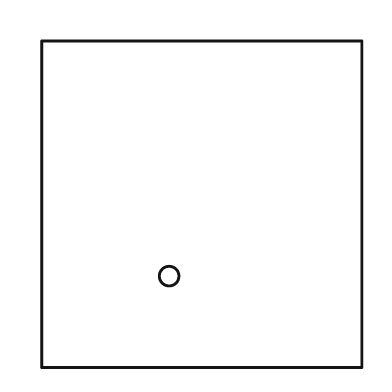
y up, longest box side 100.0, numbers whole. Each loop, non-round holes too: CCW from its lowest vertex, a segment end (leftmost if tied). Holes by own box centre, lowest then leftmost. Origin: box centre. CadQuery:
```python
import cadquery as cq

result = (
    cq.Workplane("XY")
    .moveTo(-49.0, -50.0)
    .lineTo(49.0, -50.0)
    .lineTo(49.0, 50.0)
    .lineTo(-49.0, 50.0)
    .close()
    .moveTo(-10.0, -22.0)
    .circle(3.0)
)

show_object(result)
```